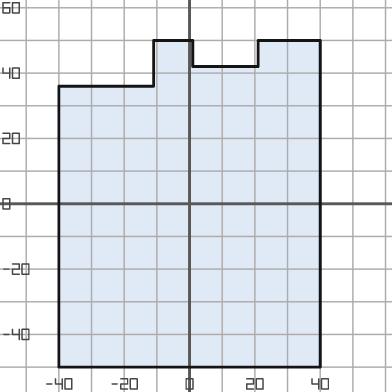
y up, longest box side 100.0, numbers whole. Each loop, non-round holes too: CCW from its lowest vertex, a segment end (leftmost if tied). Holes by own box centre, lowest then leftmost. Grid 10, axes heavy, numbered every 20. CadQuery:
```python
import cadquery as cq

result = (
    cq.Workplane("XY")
    .moveTo(-40.0, -50.0)
    .lineTo(40.0, -50.0)
    .lineTo(40.0, 50.0)
    .lineTo(21.0, 50.0)
    .lineTo(21.0, 42.0)
    .lineTo(1.0, 42.0)
    .lineTo(1.0, 50.0)
    .lineTo(-11.0, 50.0)
    .lineTo(-11.0, 36.0)
    .lineTo(-40.0, 36.0)
    .close()
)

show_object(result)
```